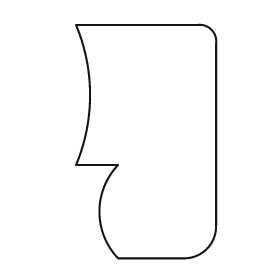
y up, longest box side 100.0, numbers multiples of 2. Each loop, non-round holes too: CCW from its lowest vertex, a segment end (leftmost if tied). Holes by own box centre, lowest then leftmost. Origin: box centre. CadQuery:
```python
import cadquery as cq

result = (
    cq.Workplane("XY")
    .moveTo(-12.0, -50.0)
    .lineTo(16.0, -50.0)
    .threePointArc((26.0, -46.0), (30.0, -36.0))
    .lineTo(30.0, 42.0)
    .threePointArc((28.0, 48.0), (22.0, 50.0))
    .lineTo(-30.0, 50.0)
    .threePointArc((-24.0, 20.0), (-30.0, -10.0))
    .lineTo(-12.0, -10.0)
    .threePointArc((-20.0, -30.0), (-12.0, -50.0))
    .close()
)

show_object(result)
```